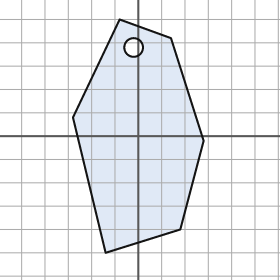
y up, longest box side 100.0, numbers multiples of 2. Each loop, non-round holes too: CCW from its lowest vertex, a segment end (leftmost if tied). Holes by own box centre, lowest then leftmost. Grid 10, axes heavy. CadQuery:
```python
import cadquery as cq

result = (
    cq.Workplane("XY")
    .moveTo(-14.0, -50.0)
    .lineTo(18.0, -40.0)
    .lineTo(28.0, -2.0)
    .lineTo(14.0, 42.0)
    .lineTo(-8.0, 50.0)
    .lineTo(-28.0, 8.0)
    .close()
    .moveTo(-2.0, 38.0)
    .circle(4.0)
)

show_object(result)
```